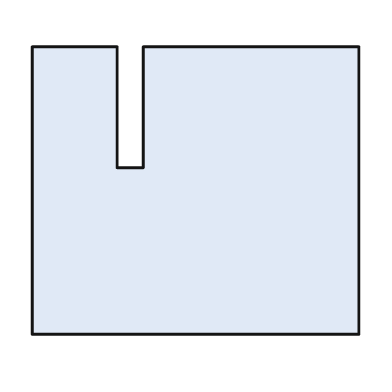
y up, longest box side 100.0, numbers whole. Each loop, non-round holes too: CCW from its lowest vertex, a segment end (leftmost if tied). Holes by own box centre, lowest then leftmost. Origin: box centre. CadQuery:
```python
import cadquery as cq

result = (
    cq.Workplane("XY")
    .moveTo(-50.0, -44.0)
    .lineTo(50.0, -44.0)
    .lineTo(50.0, 44.0)
    .lineTo(-16.0, 44.0)
    .lineTo(-16.0, 7.0)
    .lineTo(-24.0, 7.0)
    .lineTo(-24.0, 44.0)
    .lineTo(-50.0, 44.0)
    .close()
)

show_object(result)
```